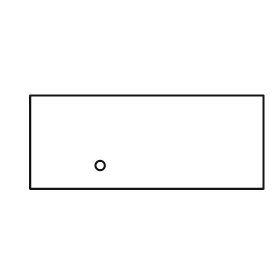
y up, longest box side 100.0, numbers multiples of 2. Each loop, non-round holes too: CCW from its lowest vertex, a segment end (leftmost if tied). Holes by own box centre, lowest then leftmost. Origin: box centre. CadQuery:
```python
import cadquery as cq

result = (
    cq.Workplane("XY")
    .moveTo(-50.0, -20.0)
    .lineTo(50.0, -20.0)
    .lineTo(50.0, 20.0)
    .lineTo(-50.0, 20.0)
    .close()
    .moveTo(-20.0, -10.0)
    .circle(2.0)
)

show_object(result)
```